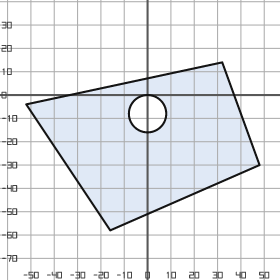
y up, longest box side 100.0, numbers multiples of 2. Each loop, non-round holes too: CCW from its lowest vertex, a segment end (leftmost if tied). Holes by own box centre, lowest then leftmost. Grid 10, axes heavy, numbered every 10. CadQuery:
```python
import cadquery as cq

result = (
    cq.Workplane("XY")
    .moveTo(-16.0, -58.0)
    .lineTo(48.0, -30.0)
    .lineTo(32.0, 14.0)
    .lineTo(-52.0, -4.0)
    .close()
    .moveTo(0.0, -8.0)
    .circle(8.0)
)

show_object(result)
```